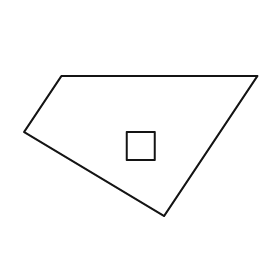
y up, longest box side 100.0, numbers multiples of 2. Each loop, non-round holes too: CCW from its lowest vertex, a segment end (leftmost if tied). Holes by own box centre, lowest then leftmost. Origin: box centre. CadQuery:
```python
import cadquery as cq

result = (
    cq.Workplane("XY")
    .moveTo(10.0, -30.0)
    .lineTo(50.0, 30.0)
    .lineTo(-34.0, 30.0)
    .lineTo(-50.0, 6.0)
    .close()
    .moveTo(-6.0, -6.0)
    .lineTo(6.0, -6.0)
    .lineTo(6.0, 6.0)
    .lineTo(-6.0, 6.0)
    .close()
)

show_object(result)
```